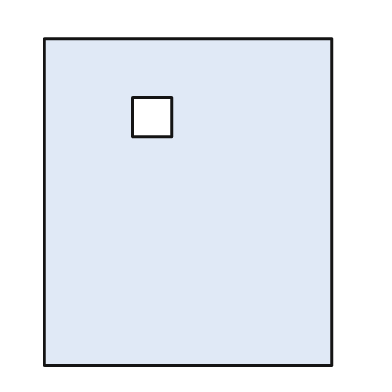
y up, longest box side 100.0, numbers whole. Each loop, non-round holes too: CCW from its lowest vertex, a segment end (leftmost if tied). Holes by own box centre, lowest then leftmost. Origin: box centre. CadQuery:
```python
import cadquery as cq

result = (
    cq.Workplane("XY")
    .moveTo(-44.0, -50.0)
    .lineTo(44.0, -50.0)
    .lineTo(44.0, 50.0)
    .lineTo(-44.0, 50.0)
    .close()
    .moveTo(-17.0, 20.0)
    .lineTo(-5.0, 20.0)
    .lineTo(-5.0, 32.0)
    .lineTo(-17.0, 32.0)
    .close()
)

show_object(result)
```